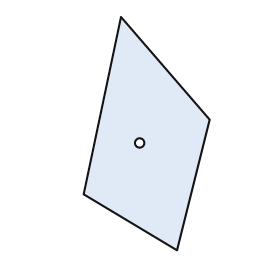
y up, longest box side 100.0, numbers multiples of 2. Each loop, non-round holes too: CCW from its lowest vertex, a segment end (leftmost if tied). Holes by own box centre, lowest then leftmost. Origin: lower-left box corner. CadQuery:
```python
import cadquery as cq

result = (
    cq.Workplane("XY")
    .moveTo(40.0, 0.0)
    .lineTo(54.0, 56.0)
    .lineTo(16.0, 100.0)
    .lineTo(0.0, 24.0)
    .close()
    .moveTo(24.0, 46.0)
    .circle(2.0)
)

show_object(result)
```